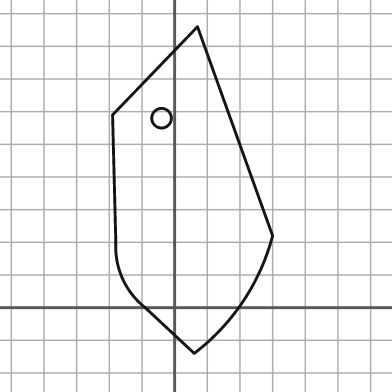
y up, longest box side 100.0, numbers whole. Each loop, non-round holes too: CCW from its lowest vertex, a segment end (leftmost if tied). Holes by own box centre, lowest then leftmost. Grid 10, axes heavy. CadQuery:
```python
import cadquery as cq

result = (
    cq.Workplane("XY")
    .moveTo(6.0, -14.0)
    .threePointArc((21.0, 2.0), (30.0, 22.0))
    .lineTo(7.0, 86.0)
    .lineTo(-19.0, 59.0)
    .lineTo(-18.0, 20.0)
    .threePointArc((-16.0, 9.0), (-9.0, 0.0))
    .close()
    .moveTo(-4.0, 58.0)
    .circle(3.0)
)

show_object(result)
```